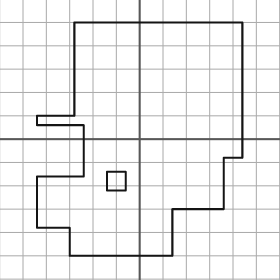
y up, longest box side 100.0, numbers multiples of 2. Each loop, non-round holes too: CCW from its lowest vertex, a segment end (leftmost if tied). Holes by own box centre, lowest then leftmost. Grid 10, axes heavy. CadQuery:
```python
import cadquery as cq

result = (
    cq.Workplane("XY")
    .moveTo(-30.0, -50.0)
    .lineTo(14.0, -50.0)
    .lineTo(14.0, -30.0)
    .lineTo(36.0, -30.0)
    .lineTo(36.0, -8.0)
    .lineTo(44.0, -8.0)
    .lineTo(44.0, 50.0)
    .lineTo(-28.0, 50.0)
    .lineTo(-28.0, 10.0)
    .lineTo(-44.0, 10.0)
    .lineTo(-44.0, 6.0)
    .lineTo(-24.0, 6.0)
    .lineTo(-24.0, -16.0)
    .lineTo(-44.0, -16.0)
    .lineTo(-44.0, -38.0)
    .lineTo(-30.0, -38.0)
    .close()
    .moveTo(-14.0, -22.0)
    .lineTo(-6.0, -22.0)
    .lineTo(-6.0, -14.0)
    .lineTo(-14.0, -14.0)
    .close()
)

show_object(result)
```